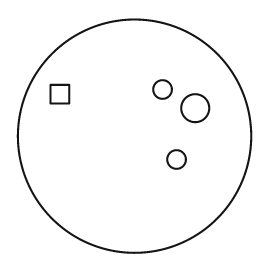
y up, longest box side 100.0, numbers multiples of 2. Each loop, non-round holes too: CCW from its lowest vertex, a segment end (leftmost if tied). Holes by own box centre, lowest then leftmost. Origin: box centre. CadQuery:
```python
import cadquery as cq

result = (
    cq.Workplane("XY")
    .moveTo(0.0, 0.0)
    .circle(50.0)
    .moveTo(18.0, -10.0)
    .circle(4.0)
    .moveTo(26.0, 12.0)
    .circle(6.0)
    .moveTo(-36.0, 14.0)
    .lineTo(-28.0, 14.0)
    .lineTo(-28.0, 22.0)
    .lineTo(-36.0, 22.0)
    .close()
    .moveTo(12.0, 20.0)
    .circle(4.0)
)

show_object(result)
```